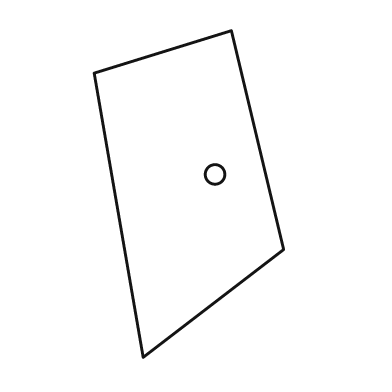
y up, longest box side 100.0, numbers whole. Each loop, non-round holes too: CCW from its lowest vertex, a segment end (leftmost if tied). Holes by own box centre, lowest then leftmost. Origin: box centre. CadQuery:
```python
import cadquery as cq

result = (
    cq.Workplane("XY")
    .moveTo(-14.0, -50.0)
    .lineTo(29.0, -17.0)
    .lineTo(13.0, 50.0)
    .lineTo(-29.0, 37.0)
    .close()
    .moveTo(8.0, 6.0)
    .circle(3.0)
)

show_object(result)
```